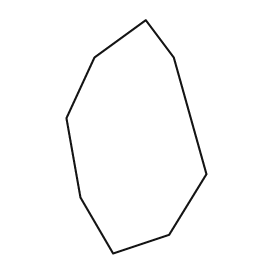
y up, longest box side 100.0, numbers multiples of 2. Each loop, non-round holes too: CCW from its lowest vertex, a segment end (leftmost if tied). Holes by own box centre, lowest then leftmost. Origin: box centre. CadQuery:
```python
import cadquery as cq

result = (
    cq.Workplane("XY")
    .moveTo(-10.0, -50.0)
    .lineTo(14.0, -42.0)
    .lineTo(30.0, -16.0)
    .lineTo(16.0, 34.0)
    .lineTo(4.0, 50.0)
    .lineTo(-18.0, 34.0)
    .lineTo(-30.0, 8.0)
    .lineTo(-24.0, -26.0)
    .close()
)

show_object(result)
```